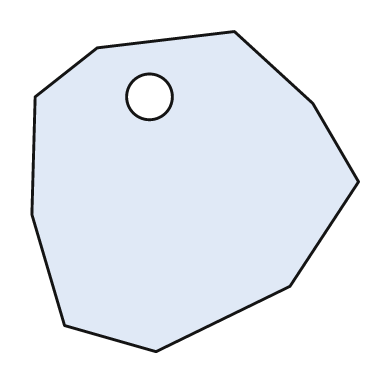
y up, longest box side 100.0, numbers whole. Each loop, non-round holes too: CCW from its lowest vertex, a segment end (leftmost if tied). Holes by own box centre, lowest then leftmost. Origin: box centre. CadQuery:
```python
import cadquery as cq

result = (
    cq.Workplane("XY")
    .moveTo(-12.0, -49.0)
    .lineTo(29.0, -29.0)
    .lineTo(50.0, 3.0)
    .lineTo(36.0, 27.0)
    .lineTo(12.0, 49.0)
    .lineTo(-30.0, 44.0)
    .lineTo(-49.0, 29.0)
    .lineTo(-50.0, -7.0)
    .lineTo(-40.0, -41.0)
    .close()
    .moveTo(-14.0, 29.0)
    .circle(7.0)
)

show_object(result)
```